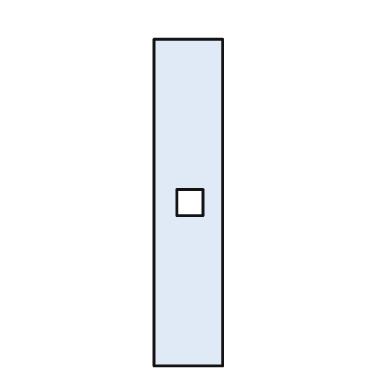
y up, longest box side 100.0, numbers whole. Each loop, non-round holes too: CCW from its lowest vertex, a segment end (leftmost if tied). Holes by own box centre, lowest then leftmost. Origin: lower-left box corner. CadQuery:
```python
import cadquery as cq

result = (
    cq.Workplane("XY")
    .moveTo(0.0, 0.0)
    .lineTo(21.0, 0.0)
    .lineTo(21.0, 100.0)
    .lineTo(0.0, 100.0)
    .close()
    .moveTo(7.0, 46.0)
    .lineTo(15.0, 46.0)
    .lineTo(15.0, 54.0)
    .lineTo(7.0, 54.0)
    .close()
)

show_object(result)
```